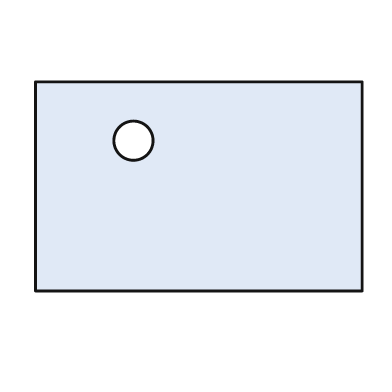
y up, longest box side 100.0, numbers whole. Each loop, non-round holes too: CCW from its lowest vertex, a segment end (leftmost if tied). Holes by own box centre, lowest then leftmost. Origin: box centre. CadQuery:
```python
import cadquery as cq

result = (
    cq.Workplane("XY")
    .moveTo(-50.0, -32.0)
    .lineTo(50.0, -32.0)
    .lineTo(50.0, 32.0)
    .lineTo(-50.0, 32.0)
    .close()
    .moveTo(-20.0, 14.0)
    .circle(6.0)
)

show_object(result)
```